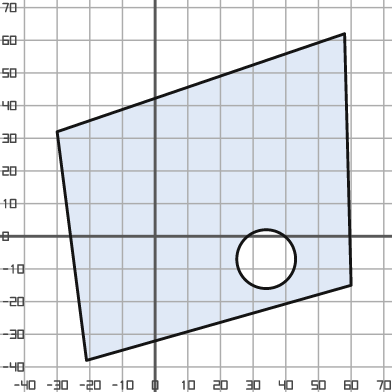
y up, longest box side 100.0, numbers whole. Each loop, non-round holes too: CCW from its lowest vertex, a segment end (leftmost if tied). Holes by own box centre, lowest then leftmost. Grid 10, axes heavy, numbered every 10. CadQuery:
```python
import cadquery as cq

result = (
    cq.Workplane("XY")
    .moveTo(-21.0, -38.0)
    .lineTo(60.0, -15.0)
    .lineTo(58.0, 62.0)
    .lineTo(-30.0, 32.0)
    .close()
    .moveTo(34.0, -7.0)
    .circle(9.0)
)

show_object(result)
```